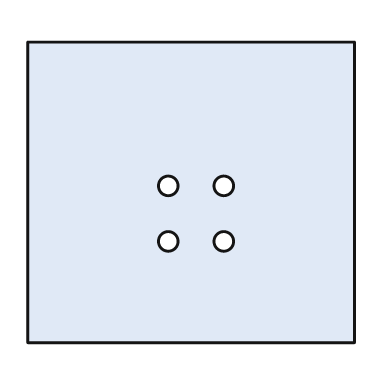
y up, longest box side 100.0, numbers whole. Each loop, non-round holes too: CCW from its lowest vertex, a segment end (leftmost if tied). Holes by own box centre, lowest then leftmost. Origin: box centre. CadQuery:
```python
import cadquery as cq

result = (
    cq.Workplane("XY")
    .moveTo(-50.0, -46.0)
    .lineTo(50.0, -46.0)
    .lineTo(50.0, 46.0)
    .lineTo(-50.0, 46.0)
    .close()
    .moveTo(-7.0, -15.0)
    .circle(3.0)
    .moveTo(10.0, -15.0)
    .circle(3.0)
    .moveTo(-7.0, 2.0)
    .circle(3.0)
    .moveTo(10.0, 2.0)
    .circle(3.0)
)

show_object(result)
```